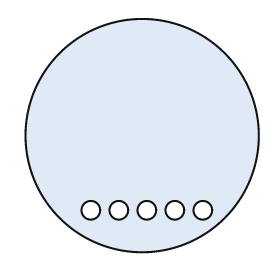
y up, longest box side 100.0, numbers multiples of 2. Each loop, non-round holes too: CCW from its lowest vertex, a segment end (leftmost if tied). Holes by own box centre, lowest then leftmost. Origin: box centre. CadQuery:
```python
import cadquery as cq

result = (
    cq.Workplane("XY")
    .moveTo(0.0, 0.0)
    .circle(50.0)
    .moveTo(-22.0, -32.0)
    .circle(4.0)
    .moveTo(-10.0, -32.0)
    .circle(4.0)
    .moveTo(2.0, -32.0)
    .circle(4.0)
    .moveTo(14.0, -32.0)
    .circle(4.0)
    .moveTo(26.0, -32.0)
    .circle(4.0)
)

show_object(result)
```